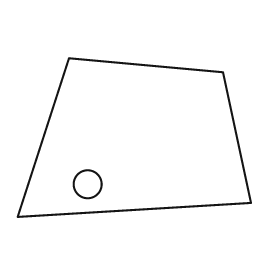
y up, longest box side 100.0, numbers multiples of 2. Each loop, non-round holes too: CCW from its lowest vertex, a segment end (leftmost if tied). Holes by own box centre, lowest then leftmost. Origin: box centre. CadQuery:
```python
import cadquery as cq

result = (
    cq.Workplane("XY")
    .moveTo(-50.0, -34.0)
    .lineTo(50.0, -28.0)
    .lineTo(38.0, 28.0)
    .lineTo(-28.0, 34.0)
    .close()
    .moveTo(-20.0, -20.0)
    .circle(6.0)
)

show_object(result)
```